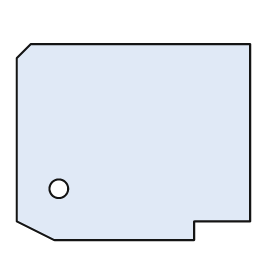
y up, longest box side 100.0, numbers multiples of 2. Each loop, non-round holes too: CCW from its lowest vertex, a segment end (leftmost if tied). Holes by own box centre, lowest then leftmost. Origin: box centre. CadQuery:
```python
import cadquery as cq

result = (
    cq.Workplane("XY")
    .moveTo(-34.0, -42.0)
    .lineTo(26.0, -42.0)
    .lineTo(26.0, -34.0)
    .lineTo(50.0, -34.0)
    .lineTo(50.0, 42.0)
    .lineTo(-44.0, 42.0)
    .lineTo(-50.0, 36.0)
    .lineTo(-50.0, -34.0)
    .close()
    .moveTo(-32.0, -20.0)
    .circle(4.0)
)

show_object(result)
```